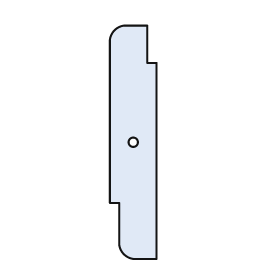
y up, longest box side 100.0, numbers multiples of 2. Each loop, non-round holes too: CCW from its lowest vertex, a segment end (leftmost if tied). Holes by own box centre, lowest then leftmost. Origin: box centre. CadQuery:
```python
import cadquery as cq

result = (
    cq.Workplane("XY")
    .moveTo(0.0, -50.0)
    .lineTo(10.0, -50.0)
    .lineTo(10.0, 34.0)
    .lineTo(6.0, 34.0)
    .lineTo(6.0, 50.0)
    .lineTo(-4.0, 50.0)
    .threePointArc((-8.0, 48.0), (-10.0, 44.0))
    .lineTo(-10.0, -26.0)
    .lineTo(-6.0, -26.0)
    .lineTo(-6.0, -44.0)
    .threePointArc((-4.0, -48.0), (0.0, -50.0))
    .close()
    .moveTo(0.0, 0.0)
    .circle(2.0)
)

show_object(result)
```